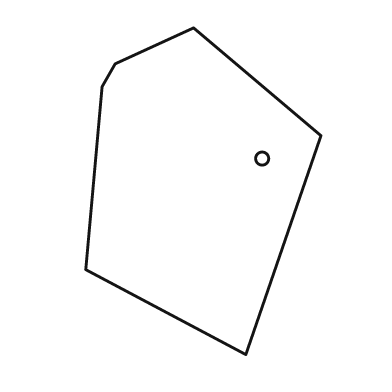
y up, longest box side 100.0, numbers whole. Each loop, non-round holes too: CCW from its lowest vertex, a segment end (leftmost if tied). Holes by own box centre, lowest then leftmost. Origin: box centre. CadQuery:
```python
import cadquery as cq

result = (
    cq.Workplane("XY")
    .moveTo(13.0, -50.0)
    .lineTo(36.0, 17.0)
    .lineTo(-3.0, 50.0)
    .lineTo(-27.0, 39.0)
    .lineTo(-31.0, 32.0)
    .lineTo(-36.0, -24.0)
    .close()
    .moveTo(18.0, 10.0)
    .circle(2.0)
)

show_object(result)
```